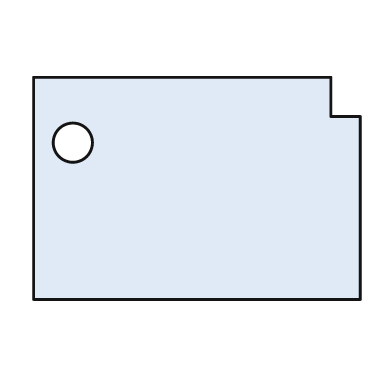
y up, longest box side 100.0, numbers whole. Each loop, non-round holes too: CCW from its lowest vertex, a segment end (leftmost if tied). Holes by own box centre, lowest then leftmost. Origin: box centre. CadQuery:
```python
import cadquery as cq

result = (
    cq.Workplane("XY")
    .moveTo(-50.0, -34.0)
    .lineTo(50.0, -34.0)
    .lineTo(50.0, 22.0)
    .lineTo(41.0, 22.0)
    .lineTo(41.0, 34.0)
    .lineTo(-50.0, 34.0)
    .close()
    .moveTo(-38.0, 14.0)
    .circle(6.0)
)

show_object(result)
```